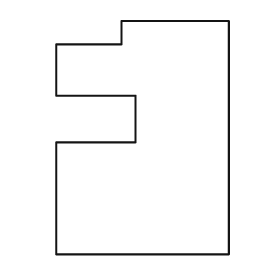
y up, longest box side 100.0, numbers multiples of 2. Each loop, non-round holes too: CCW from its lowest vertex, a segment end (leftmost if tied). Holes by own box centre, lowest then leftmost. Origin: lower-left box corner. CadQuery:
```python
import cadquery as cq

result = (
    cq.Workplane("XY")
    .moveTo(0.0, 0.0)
    .lineTo(74.0, 0.0)
    .lineTo(74.0, 100.0)
    .lineTo(28.0, 100.0)
    .lineTo(28.0, 90.0)
    .lineTo(0.0, 90.0)
    .lineTo(0.0, 68.0)
    .lineTo(34.0, 68.0)
    .lineTo(34.0, 48.0)
    .lineTo(0.0, 48.0)
    .close()
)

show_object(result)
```